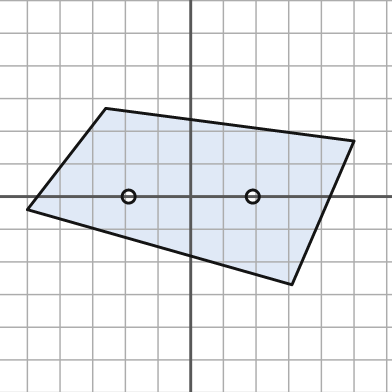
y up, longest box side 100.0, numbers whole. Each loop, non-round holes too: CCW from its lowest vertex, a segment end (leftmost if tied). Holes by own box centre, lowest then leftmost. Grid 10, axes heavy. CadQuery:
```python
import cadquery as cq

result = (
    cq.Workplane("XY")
    .moveTo(31.0, -27.0)
    .lineTo(50.0, 17.0)
    .lineTo(-26.0, 27.0)
    .lineTo(-50.0, -4.0)
    .close()
    .moveTo(-19.0, 0.0)
    .circle(2.0)
    .moveTo(19.0, 0.0)
    .circle(2.0)
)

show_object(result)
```